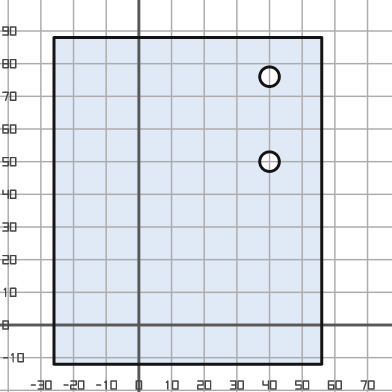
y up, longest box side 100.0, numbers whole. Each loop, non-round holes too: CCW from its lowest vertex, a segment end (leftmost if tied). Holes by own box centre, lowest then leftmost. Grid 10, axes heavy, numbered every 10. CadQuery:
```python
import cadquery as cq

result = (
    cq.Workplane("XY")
    .moveTo(-26.0, -12.0)
    .lineTo(56.0, -12.0)
    .lineTo(56.0, 88.0)
    .lineTo(-26.0, 88.0)
    .close()
    .moveTo(40.0, 50.0)
    .circle(3.0)
    .moveTo(40.0, 76.0)
    .circle(3.0)
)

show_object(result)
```